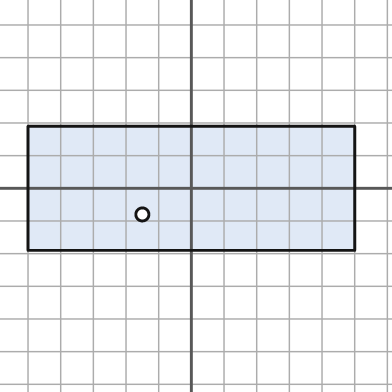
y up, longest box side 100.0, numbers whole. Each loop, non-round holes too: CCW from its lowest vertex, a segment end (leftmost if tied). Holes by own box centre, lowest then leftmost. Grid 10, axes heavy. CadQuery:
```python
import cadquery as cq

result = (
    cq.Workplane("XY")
    .moveTo(-50.0, -19.0)
    .lineTo(50.0, -19.0)
    .lineTo(50.0, 19.0)
    .lineTo(-50.0, 19.0)
    .close()
    .moveTo(-15.0, -8.0)
    .circle(2.0)
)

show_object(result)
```